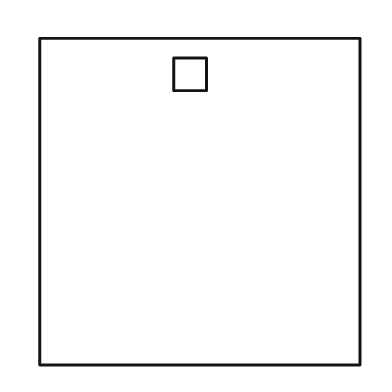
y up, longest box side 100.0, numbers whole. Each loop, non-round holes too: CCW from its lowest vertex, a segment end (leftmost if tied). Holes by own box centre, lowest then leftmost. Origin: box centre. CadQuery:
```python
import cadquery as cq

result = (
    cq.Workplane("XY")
    .moveTo(-49.0, -50.0)
    .lineTo(49.0, -50.0)
    .lineTo(49.0, 50.0)
    .lineTo(-49.0, 50.0)
    .close()
    .moveTo(-8.0, 34.0)
    .lineTo(2.0, 34.0)
    .lineTo(2.0, 44.0)
    .lineTo(-8.0, 44.0)
    .close()
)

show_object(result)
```